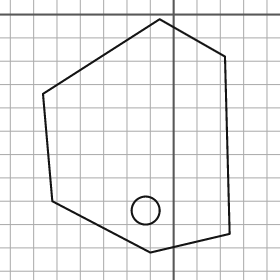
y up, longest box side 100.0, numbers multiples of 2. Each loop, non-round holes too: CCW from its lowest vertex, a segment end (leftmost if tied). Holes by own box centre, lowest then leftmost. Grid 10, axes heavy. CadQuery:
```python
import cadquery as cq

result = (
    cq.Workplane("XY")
    .moveTo(-10.0, -102.0)
    .lineTo(24.0, -94.0)
    .lineTo(22.0, -18.0)
    .lineTo(-6.0, -2.0)
    .lineTo(-56.0, -34.0)
    .lineTo(-52.0, -80.0)
    .close()
    .moveTo(-12.0, -84.0)
    .circle(6.0)
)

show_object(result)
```